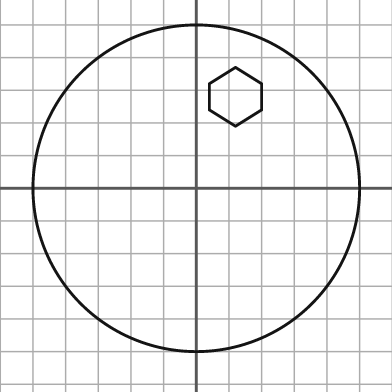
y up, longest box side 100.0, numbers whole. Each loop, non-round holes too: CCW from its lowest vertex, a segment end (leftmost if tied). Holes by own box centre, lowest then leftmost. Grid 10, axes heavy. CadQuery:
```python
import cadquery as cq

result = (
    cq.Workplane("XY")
    .moveTo(0.0, 0.0)
    .circle(50.0)
    .moveTo(12.0, 19.0)
    .lineTo(20.0, 24.0)
    .lineTo(20.0, 32.0)
    .lineTo(12.0, 37.0)
    .lineTo(4.0, 32.0)
    .lineTo(4.0, 24.0)
    .close()
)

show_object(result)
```